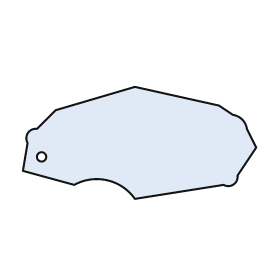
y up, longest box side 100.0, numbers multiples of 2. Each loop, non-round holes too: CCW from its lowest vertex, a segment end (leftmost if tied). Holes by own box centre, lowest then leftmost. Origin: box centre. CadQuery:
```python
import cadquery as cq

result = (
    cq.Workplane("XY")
    .moveTo(-2.0, -24.0)
    .lineTo(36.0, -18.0)
    .threePointArc((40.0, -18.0), (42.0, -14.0))
    .lineTo(50.0, -2.0)
    .lineTo(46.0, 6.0)
    .threePointArc((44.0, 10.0), (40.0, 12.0))
    .lineTo(34.0, 16.0)
    .lineTo(-2.0, 24.0)
    .lineTo(-36.0, 14.0)
    .lineTo(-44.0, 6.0)
    .threePointArc((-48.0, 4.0), (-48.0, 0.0))
    .lineTo(-50.0, -12.0)
    .lineTo(-28.0, -18.0)
    .threePointArc((-14.0, -16.0), (-2.0, -24.0))
    .close()
    .moveTo(-42.0, -6.0)
    .circle(2.0)
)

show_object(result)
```